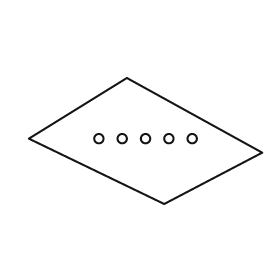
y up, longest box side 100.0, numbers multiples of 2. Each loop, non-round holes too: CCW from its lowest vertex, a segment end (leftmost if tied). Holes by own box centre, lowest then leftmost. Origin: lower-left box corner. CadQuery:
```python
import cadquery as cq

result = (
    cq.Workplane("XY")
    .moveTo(58.0, 0.0)
    .lineTo(100.0, 22.0)
    .lineTo(42.0, 54.0)
    .lineTo(0.0, 28.0)
    .close()
    .moveTo(30.0, 28.0)
    .circle(2.0)
    .moveTo(40.0, 28.0)
    .circle(2.0)
    .moveTo(50.0, 28.0)
    .circle(2.0)
    .moveTo(60.0, 28.0)
    .circle(2.0)
    .moveTo(70.0, 28.0)
    .circle(2.0)
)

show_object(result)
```